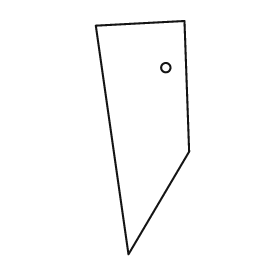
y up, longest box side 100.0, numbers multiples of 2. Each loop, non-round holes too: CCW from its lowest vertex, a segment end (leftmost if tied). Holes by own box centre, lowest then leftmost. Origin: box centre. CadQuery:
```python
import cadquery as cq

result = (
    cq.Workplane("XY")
    .moveTo(-6.0, -50.0)
    .lineTo(20.0, -6.0)
    .lineTo(18.0, 50.0)
    .lineTo(-20.0, 48.0)
    .close()
    .moveTo(10.0, 30.0)
    .circle(2.0)
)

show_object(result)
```